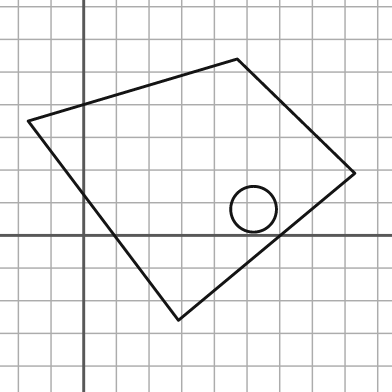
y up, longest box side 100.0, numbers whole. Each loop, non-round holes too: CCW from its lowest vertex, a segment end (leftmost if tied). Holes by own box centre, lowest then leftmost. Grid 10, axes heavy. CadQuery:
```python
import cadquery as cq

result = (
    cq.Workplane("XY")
    .moveTo(29.0, -26.0)
    .lineTo(83.0, 19.0)
    .lineTo(47.0, 54.0)
    .lineTo(-17.0, 35.0)
    .close()
    .moveTo(52.0, 8.0)
    .circle(7.0)
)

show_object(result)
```